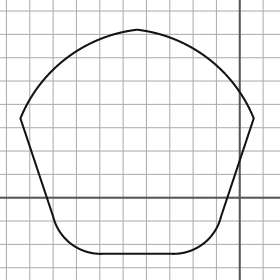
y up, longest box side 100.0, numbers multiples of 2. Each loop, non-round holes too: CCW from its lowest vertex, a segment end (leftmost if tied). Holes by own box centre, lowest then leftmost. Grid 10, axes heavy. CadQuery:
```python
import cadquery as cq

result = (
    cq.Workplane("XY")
    .moveTo(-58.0, -24.0)
    .lineTo(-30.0, -24.0)
    .threePointArc((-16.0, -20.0), (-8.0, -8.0))
    .lineTo(6.0, 34.0)
    .threePointArc((-14.0, 60.0), (-44.0, 72.0))
    .threePointArc((-74.0, 60.0), (-94.0, 34.0))
    .lineTo(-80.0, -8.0)
    .threePointArc((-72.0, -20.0), (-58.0, -24.0))
    .close()
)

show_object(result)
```